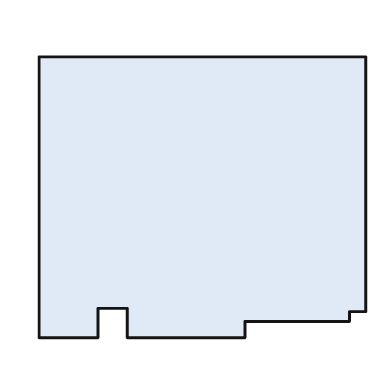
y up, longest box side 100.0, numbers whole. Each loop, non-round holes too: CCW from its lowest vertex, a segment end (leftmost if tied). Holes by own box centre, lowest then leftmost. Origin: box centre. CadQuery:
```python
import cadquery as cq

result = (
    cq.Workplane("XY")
    .moveTo(-50.0, -43.0)
    .lineTo(-32.0, -43.0)
    .lineTo(-32.0, -34.0)
    .lineTo(-23.0, -34.0)
    .lineTo(-23.0, -43.0)
    .lineTo(13.0, -43.0)
    .lineTo(13.0, -38.0)
    .lineTo(45.0, -38.0)
    .lineTo(45.0, -35.0)
    .lineTo(50.0, -35.0)
    .lineTo(50.0, 43.0)
    .lineTo(-50.0, 43.0)
    .close()
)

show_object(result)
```